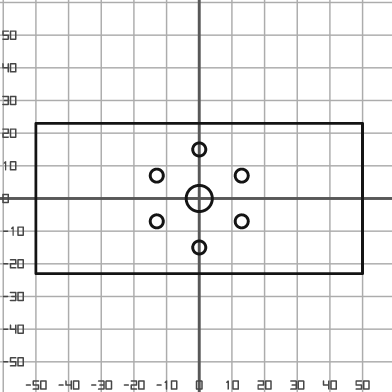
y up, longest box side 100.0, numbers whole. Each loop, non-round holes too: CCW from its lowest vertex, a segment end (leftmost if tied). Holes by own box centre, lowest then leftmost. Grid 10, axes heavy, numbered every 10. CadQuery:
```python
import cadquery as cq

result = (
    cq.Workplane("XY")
    .moveTo(-50.0, -23.0)
    .lineTo(50.0, -23.0)
    .lineTo(50.0, 23.0)
    .lineTo(-50.0, 23.0)
    .close()
    .moveTo(0.0, -15.0)
    .circle(2.0)
    .moveTo(-13.0, -7.0)
    .circle(2.0)
    .moveTo(13.0, -7.0)
    .circle(2.0)
    .moveTo(0.0, 0.0)
    .circle(4.0)
    .moveTo(-13.0, 7.0)
    .circle(2.0)
    .moveTo(13.0, 7.0)
    .circle(2.0)
    .moveTo(0.0, 15.0)
    .circle(2.0)
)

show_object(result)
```